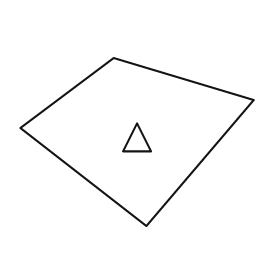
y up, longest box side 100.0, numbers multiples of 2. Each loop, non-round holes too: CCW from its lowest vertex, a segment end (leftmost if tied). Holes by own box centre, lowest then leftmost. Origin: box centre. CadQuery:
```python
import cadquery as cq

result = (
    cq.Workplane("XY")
    .moveTo(4.0, -36.0)
    .lineTo(50.0, 18.0)
    .lineTo(-10.0, 36.0)
    .lineTo(-50.0, 6.0)
    .close()
    .moveTo(-6.0, -4.0)
    .lineTo(6.0, -4.0)
    .lineTo(0.0, 8.0)
    .close()
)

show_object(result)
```